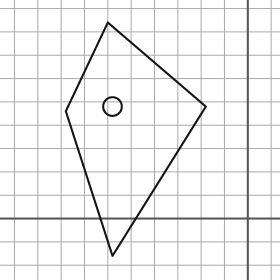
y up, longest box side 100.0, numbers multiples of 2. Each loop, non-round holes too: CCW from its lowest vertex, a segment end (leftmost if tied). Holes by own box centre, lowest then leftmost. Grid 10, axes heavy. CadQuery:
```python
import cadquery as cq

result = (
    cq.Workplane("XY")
    .moveTo(-58.0, -16.0)
    .lineTo(-18.0, 48.0)
    .lineTo(-60.0, 84.0)
    .lineTo(-78.0, 46.0)
    .close()
    .moveTo(-58.0, 48.0)
    .circle(4.0)
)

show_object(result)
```